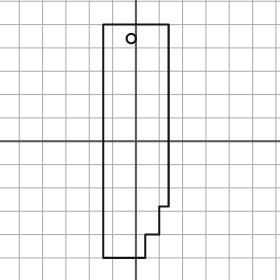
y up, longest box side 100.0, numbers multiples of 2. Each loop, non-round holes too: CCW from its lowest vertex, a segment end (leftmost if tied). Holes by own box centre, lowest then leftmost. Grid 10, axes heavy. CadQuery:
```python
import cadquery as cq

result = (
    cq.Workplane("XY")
    .moveTo(-14.0, -50.0)
    .lineTo(4.0, -50.0)
    .lineTo(4.0, -40.0)
    .lineTo(10.0, -40.0)
    .lineTo(10.0, -28.0)
    .lineTo(14.0, -28.0)
    .lineTo(14.0, 50.0)
    .lineTo(-14.0, 50.0)
    .close()
    .moveTo(-2.0, 44.0)
    .circle(2.0)
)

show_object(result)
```